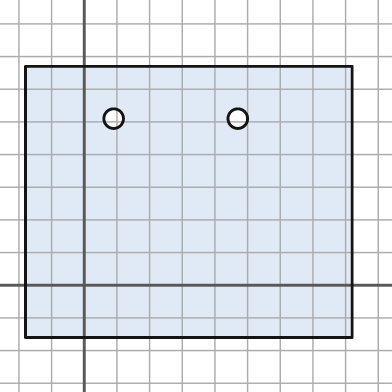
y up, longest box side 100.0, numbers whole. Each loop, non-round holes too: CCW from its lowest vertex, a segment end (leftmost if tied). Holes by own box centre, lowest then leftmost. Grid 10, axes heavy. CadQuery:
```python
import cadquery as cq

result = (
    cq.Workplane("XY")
    .moveTo(-18.0, -16.0)
    .lineTo(82.0, -16.0)
    .lineTo(82.0, 67.0)
    .lineTo(-18.0, 67.0)
    .close()
    .moveTo(9.0, 51.0)
    .circle(3.0)
    .moveTo(47.0, 51.0)
    .circle(3.0)
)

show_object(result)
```